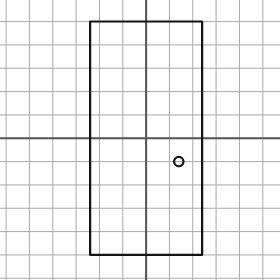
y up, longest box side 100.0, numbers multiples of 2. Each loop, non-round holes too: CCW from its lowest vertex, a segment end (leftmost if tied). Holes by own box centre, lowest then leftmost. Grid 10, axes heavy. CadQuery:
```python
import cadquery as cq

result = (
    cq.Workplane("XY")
    .moveTo(-24.0, -50.0)
    .lineTo(24.0, -50.0)
    .lineTo(24.0, 50.0)
    .lineTo(-24.0, 50.0)
    .close()
    .moveTo(14.0, -10.0)
    .circle(2.0)
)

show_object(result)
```